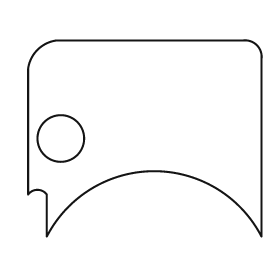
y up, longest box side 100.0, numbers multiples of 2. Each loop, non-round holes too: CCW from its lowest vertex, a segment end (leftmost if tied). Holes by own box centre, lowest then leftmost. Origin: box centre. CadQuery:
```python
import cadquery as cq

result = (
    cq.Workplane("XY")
    .moveTo(-42.0, -42.0)
    .threePointArc((4.0, -14.0), (50.0, -42.0))
    .lineTo(50.0, 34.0)
    .threePointArc((48.0, 40.0), (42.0, 42.0))
    .lineTo(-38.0, 42.0)
    .threePointArc((-46.0, 38.0), (-50.0, 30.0))
    .lineTo(-50.0, -24.0)
    .threePointArc((-46.0, -22.0), (-42.0, -24.0))
    .close()
    .moveTo(-36.0, 0.0)
    .circle(10.0)
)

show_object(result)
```